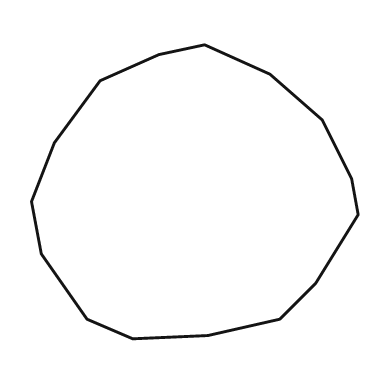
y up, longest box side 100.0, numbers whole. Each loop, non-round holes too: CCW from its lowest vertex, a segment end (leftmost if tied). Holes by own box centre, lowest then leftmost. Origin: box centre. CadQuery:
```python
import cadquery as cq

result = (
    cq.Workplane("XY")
    .moveTo(-19.0, -45.0)
    .lineTo(4.0, -44.0)
    .lineTo(26.0, -39.0)
    .lineTo(37.0, -28.0)
    .lineTo(50.0, -7.0)
    .lineTo(48.0, 4.0)
    .lineTo(39.0, 22.0)
    .lineTo(23.0, 36.0)
    .lineTo(3.0, 45.0)
    .lineTo(-11.0, 42.0)
    .lineTo(-29.0, 34.0)
    .lineTo(-43.0, 15.0)
    .lineTo(-50.0, -3.0)
    .lineTo(-47.0, -19.0)
    .lineTo(-33.0, -39.0)
    .close()
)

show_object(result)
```